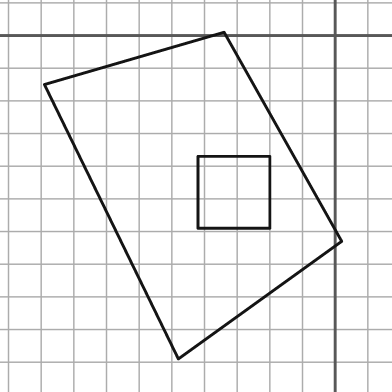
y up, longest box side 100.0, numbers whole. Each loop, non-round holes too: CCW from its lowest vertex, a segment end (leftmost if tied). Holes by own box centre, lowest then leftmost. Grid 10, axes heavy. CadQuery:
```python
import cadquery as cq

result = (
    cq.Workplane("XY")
    .moveTo(-48.0, -99.0)
    .lineTo(2.0, -63.0)
    .lineTo(-34.0, 1.0)
    .lineTo(-89.0, -15.0)
    .close()
    .moveTo(-42.0, -59.0)
    .lineTo(-20.0, -59.0)
    .lineTo(-20.0, -37.0)
    .lineTo(-42.0, -37.0)
    .close()
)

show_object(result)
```